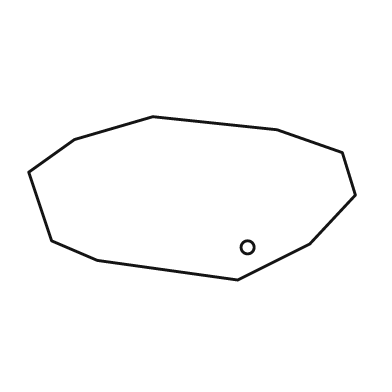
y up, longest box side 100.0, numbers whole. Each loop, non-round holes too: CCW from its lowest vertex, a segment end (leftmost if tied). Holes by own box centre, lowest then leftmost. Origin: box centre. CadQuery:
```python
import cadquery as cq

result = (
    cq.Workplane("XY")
    .moveTo(14.0, -25.0)
    .lineTo(36.0, -14.0)
    .lineTo(50.0, 1.0)
    .lineTo(46.0, 14.0)
    .lineTo(26.0, 21.0)
    .lineTo(-12.0, 25.0)
    .lineTo(-36.0, 18.0)
    .lineTo(-50.0, 8.0)
    .lineTo(-43.0, -13.0)
    .lineTo(-29.0, -19.0)
    .close()
    .moveTo(17.0, -15.0)
    .circle(2.0)
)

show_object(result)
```